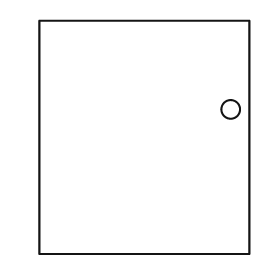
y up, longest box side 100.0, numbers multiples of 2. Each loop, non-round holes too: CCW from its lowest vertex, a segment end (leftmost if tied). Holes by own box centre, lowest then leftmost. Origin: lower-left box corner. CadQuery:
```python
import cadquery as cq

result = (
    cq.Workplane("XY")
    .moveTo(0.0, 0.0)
    .lineTo(90.0, 0.0)
    .lineTo(90.0, 100.0)
    .lineTo(0.0, 100.0)
    .close()
    .moveTo(82.0, 62.0)
    .circle(4.0)
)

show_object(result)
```